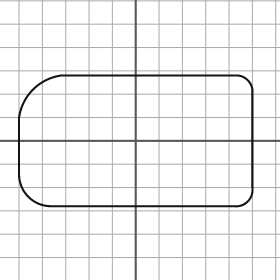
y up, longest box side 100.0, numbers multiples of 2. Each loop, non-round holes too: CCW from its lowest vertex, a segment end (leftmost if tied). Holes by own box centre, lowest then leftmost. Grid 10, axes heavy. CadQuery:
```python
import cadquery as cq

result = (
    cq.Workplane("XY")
    .moveTo(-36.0, -28.0)
    .lineTo(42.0, -28.0)
    .threePointArc((48.0, -26.0), (50.0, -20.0))
    .lineTo(50.0, 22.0)
    .threePointArc((48.0, 26.0), (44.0, 28.0))
    .lineTo(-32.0, 28.0)
    .threePointArc((-44.0, 22.0), (-50.0, 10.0))
    .lineTo(-50.0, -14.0)
    .threePointArc((-46.0, -24.0), (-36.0, -28.0))
    .close()
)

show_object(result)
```